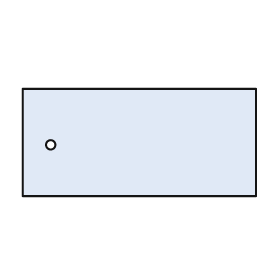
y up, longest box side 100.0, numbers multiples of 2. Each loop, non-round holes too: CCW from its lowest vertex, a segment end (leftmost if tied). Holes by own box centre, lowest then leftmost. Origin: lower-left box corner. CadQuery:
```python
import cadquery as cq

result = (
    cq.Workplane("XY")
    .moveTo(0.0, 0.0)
    .lineTo(100.0, 0.0)
    .lineTo(100.0, 46.0)
    .lineTo(0.0, 46.0)
    .close()
    .moveTo(12.0, 22.0)
    .circle(2.0)
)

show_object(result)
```